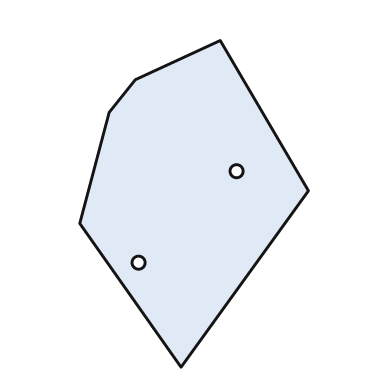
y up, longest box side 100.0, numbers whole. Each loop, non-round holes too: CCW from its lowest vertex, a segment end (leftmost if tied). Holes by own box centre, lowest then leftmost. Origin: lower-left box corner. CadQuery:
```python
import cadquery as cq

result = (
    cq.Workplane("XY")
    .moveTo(31.0, 0.0)
    .lineTo(70.0, 54.0)
    .lineTo(43.0, 100.0)
    .lineTo(17.0, 88.0)
    .lineTo(9.0, 78.0)
    .lineTo(0.0, 44.0)
    .close()
    .moveTo(18.0, 32.0)
    .circle(2.0)
    .moveTo(48.0, 60.0)
    .circle(2.0)
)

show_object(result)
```